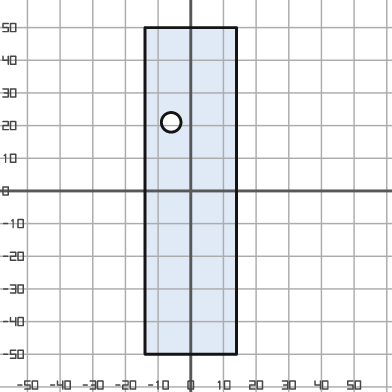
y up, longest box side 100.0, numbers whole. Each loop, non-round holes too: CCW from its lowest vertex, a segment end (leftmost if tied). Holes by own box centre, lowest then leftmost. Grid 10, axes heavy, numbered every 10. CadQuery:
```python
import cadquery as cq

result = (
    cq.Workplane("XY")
    .moveTo(-14.0, -50.0)
    .lineTo(14.0, -50.0)
    .lineTo(14.0, 50.0)
    .lineTo(-14.0, 50.0)
    .close()
    .moveTo(-6.0, 21.0)
    .circle(3.0)
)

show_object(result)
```